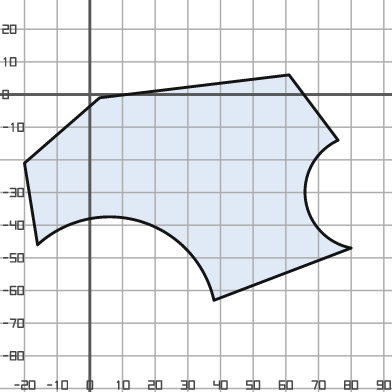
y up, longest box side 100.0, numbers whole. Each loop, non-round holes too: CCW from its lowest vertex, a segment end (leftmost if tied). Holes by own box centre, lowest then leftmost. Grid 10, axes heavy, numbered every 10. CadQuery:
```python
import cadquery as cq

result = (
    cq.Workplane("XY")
    .moveTo(38.0, -63.0)
    .lineTo(80.0, -47.0)
    .threePointArc((66.0, -32.0), (76.0, -14.0))
    .lineTo(61.0, 6.0)
    .lineTo(3.0, -1.0)
    .lineTo(-20.0, -21.0)
    .lineTo(-16.0, -46.0)
    .threePointArc((16.0, -39.0), (38.0, -63.0))
    .close()
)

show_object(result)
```